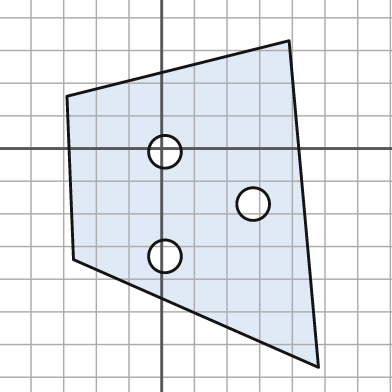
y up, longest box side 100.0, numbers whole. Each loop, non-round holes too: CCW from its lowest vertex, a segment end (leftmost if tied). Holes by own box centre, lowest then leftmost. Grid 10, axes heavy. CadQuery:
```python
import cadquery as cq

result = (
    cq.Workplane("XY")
    .moveTo(48.0, -67.0)
    .lineTo(39.0, 33.0)
    .lineTo(-29.0, 16.0)
    .lineTo(-27.0, -34.0)
    .close()
    .moveTo(1.0, -33.0)
    .circle(5.0)
    .moveTo(28.0, -17.0)
    .circle(5.0)
    .moveTo(1.0, -1.0)
    .circle(5.0)
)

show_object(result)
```